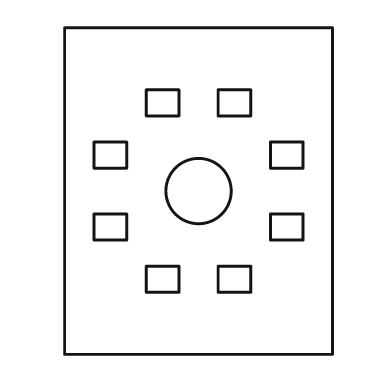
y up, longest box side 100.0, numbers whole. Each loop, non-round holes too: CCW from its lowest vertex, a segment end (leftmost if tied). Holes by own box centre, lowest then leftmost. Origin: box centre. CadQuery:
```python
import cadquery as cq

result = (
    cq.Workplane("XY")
    .moveTo(-41.0, -50.0)
    .lineTo(41.0, -50.0)
    .lineTo(41.0, 50.0)
    .lineTo(-41.0, 50.0)
    .close()
    .moveTo(-16.0, -31.0)
    .lineTo(-6.0, -31.0)
    .lineTo(-6.0, -23.0)
    .lineTo(-16.0, -23.0)
    .close()
    .moveTo(6.0, -31.0)
    .lineTo(16.0, -31.0)
    .lineTo(16.0, -23.0)
    .lineTo(6.0, -23.0)
    .close()
    .moveTo(-32.0, -15.0)
    .lineTo(-22.0, -15.0)
    .lineTo(-22.0, -7.0)
    .lineTo(-32.0, -7.0)
    .close()
    .moveTo(22.0, -15.0)
    .lineTo(32.0, -15.0)
    .lineTo(32.0, -7.0)
    .lineTo(22.0, -7.0)
    .close()
    .moveTo(0.0, 0.0)
    .circle(10.0)
    .moveTo(-32.0, 7.0)
    .lineTo(-22.0, 7.0)
    .lineTo(-22.0, 15.0)
    .lineTo(-32.0, 15.0)
    .close()
    .moveTo(22.0, 7.0)
    .lineTo(32.0, 7.0)
    .lineTo(32.0, 15.0)
    .lineTo(22.0, 15.0)
    .close()
    .moveTo(-16.0, 23.0)
    .lineTo(-6.0, 23.0)
    .lineTo(-6.0, 31.0)
    .lineTo(-16.0, 31.0)
    .close()
    .moveTo(6.0, 23.0)
    .lineTo(16.0, 23.0)
    .lineTo(16.0, 31.0)
    .lineTo(6.0, 31.0)
    .close()
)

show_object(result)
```